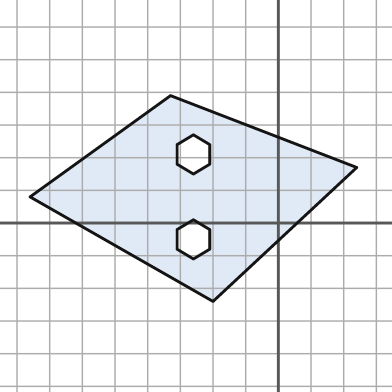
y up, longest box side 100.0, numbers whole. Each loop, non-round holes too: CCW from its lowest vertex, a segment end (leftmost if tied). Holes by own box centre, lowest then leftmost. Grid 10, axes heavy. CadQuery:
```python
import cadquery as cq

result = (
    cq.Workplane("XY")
    .moveTo(-20.0, -24.0)
    .lineTo(24.0, 17.0)
    .lineTo(-33.0, 39.0)
    .lineTo(-76.0, 8.0)
    .close()
    .moveTo(-26.0, -11.0)
    .lineTo(-21.0, -8.0)
    .lineTo(-21.0, -2.0)
    .lineTo(-26.0, 1.0)
    .lineTo(-31.0, -2.0)
    .lineTo(-31.0, -8.0)
    .close()
    .moveTo(-26.0, 15.0)
    .lineTo(-21.0, 18.0)
    .lineTo(-21.0, 24.0)
    .lineTo(-26.0, 27.0)
    .lineTo(-31.0, 24.0)
    .lineTo(-31.0, 18.0)
    .close()
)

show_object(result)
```